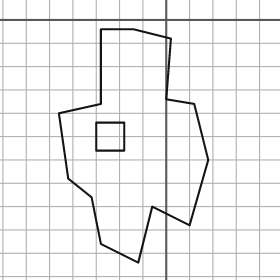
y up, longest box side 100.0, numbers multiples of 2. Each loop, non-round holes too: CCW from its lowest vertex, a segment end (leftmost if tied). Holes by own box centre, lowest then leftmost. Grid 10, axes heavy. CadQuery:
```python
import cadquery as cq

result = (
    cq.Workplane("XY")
    .moveTo(-12.0, -104.0)
    .lineTo(-6.0, -80.0)
    .lineTo(10.0, -88.0)
    .lineTo(18.0, -60.0)
    .lineTo(12.0, -36.0)
    .lineTo(0.0, -34.0)
    .lineTo(2.0, -8.0)
    .lineTo(-14.0, -4.0)
    .lineTo(-28.0, -4.0)
    .lineTo(-28.0, -36.0)
    .lineTo(-46.0, -40.0)
    .lineTo(-42.0, -68.0)
    .lineTo(-32.0, -76.0)
    .lineTo(-28.0, -96.0)
    .close()
    .moveTo(-30.0, -56.0)
    .lineTo(-18.0, -56.0)
    .lineTo(-18.0, -44.0)
    .lineTo(-30.0, -44.0)
    .close()
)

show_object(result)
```